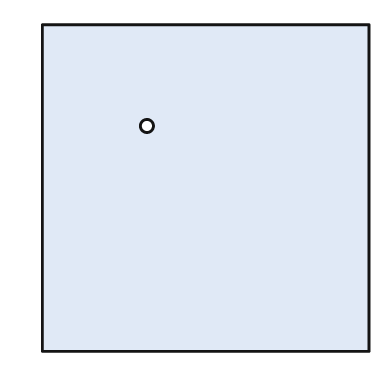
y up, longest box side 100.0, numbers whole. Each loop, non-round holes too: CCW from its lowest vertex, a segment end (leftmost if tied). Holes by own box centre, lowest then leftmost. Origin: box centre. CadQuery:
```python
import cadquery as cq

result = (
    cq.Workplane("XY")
    .moveTo(-50.0, -50.0)
    .lineTo(50.0, -50.0)
    .lineTo(50.0, 50.0)
    .lineTo(-50.0, 50.0)
    .close()
    .moveTo(-18.0, 19.0)
    .circle(2.0)
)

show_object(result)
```